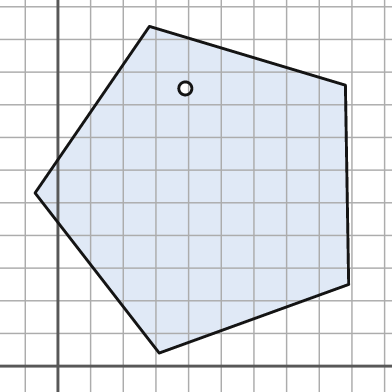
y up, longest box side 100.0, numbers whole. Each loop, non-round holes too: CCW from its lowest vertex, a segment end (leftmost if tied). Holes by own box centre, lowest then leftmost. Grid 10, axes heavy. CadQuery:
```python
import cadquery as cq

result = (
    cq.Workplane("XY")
    .moveTo(31.0, 4.0)
    .lineTo(89.0, 25.0)
    .lineTo(88.0, 86.0)
    .lineTo(28.0, 104.0)
    .lineTo(-7.0, 53.0)
    .close()
    .moveTo(39.0, 85.0)
    .circle(2.0)
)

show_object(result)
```